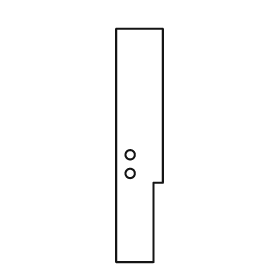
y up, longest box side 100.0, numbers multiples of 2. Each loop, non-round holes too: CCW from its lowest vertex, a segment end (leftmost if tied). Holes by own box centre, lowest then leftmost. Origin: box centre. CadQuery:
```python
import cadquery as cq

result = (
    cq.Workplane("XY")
    .moveTo(-10.0, -50.0)
    .lineTo(6.0, -50.0)
    .lineTo(6.0, -16.0)
    .lineTo(10.0, -16.0)
    .lineTo(10.0, 50.0)
    .lineTo(-10.0, 50.0)
    .close()
    .moveTo(-4.0, -12.0)
    .circle(2.0)
    .moveTo(-4.0, -4.0)
    .circle(2.0)
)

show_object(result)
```